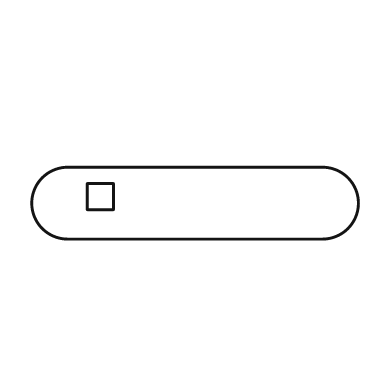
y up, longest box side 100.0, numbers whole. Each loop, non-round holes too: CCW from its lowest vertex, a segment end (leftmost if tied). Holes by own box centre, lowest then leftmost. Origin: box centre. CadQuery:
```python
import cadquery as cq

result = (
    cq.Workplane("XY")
    .moveTo(-39.0, -11.0)
    .lineTo(39.0, -11.0)
    .threePointArc((50.0, 0.0), (39.0, 11.0))
    .lineTo(-39.0, 11.0)
    .threePointArc((-50.0, 0.0), (-39.0, -11.0))
    .close()
    .moveTo(-33.0, -2.0)
    .lineTo(-25.0, -2.0)
    .lineTo(-25.0, 6.0)
    .lineTo(-33.0, 6.0)
    .close()
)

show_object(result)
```